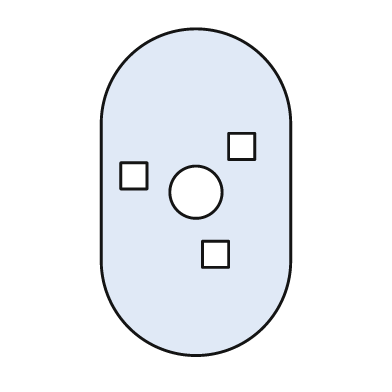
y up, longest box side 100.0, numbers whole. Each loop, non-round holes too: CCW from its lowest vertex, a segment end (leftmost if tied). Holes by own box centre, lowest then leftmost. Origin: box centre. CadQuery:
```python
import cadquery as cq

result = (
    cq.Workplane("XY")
    .moveTo(-29.0, -21.0)
    .threePointArc((0.0, -50.0), (29.0, -21.0))
    .lineTo(29.0, 21.0)
    .threePointArc((0.0, 50.0), (-29.0, 21.0))
    .close()
    .moveTo(2.0, -23.0)
    .lineTo(10.0, -23.0)
    .lineTo(10.0, -15.0)
    .lineTo(2.0, -15.0)
    .close()
    .moveTo(0.0, 0.0)
    .circle(8.0)
    .moveTo(-23.0, 1.0)
    .lineTo(-15.0, 1.0)
    .lineTo(-15.0, 9.0)
    .lineTo(-23.0, 9.0)
    .close()
    .moveTo(10.0, 10.0)
    .lineTo(18.0, 10.0)
    .lineTo(18.0, 18.0)
    .lineTo(10.0, 18.0)
    .close()
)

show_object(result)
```